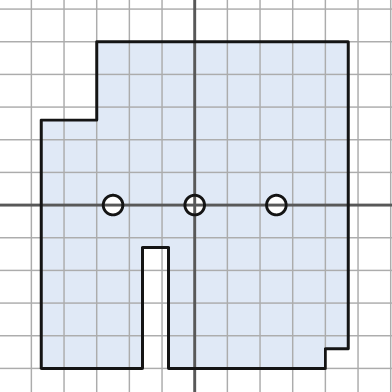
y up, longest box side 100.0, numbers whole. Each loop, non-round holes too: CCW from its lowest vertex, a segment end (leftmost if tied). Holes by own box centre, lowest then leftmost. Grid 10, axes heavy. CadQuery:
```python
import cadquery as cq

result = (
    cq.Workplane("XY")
    .moveTo(-47.0, -50.0)
    .lineTo(-16.0, -50.0)
    .lineTo(-16.0, -13.0)
    .lineTo(-8.0, -13.0)
    .lineTo(-8.0, -50.0)
    .lineTo(40.0, -50.0)
    .lineTo(40.0, -44.0)
    .lineTo(47.0, -44.0)
    .lineTo(47.0, 50.0)
    .lineTo(-30.0, 50.0)
    .lineTo(-30.0, 26.0)
    .lineTo(-47.0, 26.0)
    .close()
    .moveTo(-25.0, 0.0)
    .circle(3.0)
    .moveTo(0.0, 0.0)
    .circle(3.0)
    .moveTo(25.0, 0.0)
    .circle(3.0)
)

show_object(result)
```